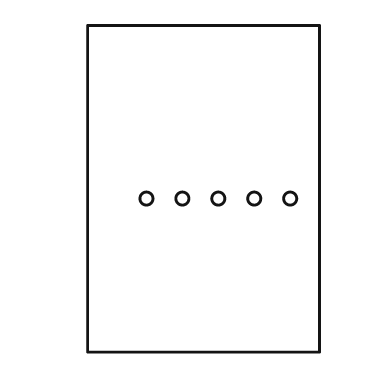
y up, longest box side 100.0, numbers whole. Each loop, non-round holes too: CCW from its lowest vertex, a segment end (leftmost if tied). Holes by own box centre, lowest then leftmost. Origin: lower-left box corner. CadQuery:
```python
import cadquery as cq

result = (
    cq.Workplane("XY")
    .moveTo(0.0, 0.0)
    .lineTo(71.0, 0.0)
    .lineTo(71.0, 100.0)
    .lineTo(0.0, 100.0)
    .close()
    .moveTo(18.0, 47.0)
    .circle(2.0)
    .moveTo(29.0, 47.0)
    .circle(2.0)
    .moveTo(40.0, 47.0)
    .circle(2.0)
    .moveTo(51.0, 47.0)
    .circle(2.0)
    .moveTo(62.0, 47.0)
    .circle(2.0)
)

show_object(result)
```